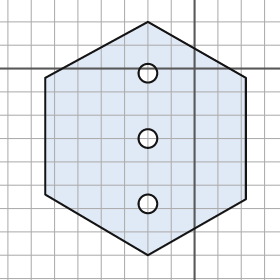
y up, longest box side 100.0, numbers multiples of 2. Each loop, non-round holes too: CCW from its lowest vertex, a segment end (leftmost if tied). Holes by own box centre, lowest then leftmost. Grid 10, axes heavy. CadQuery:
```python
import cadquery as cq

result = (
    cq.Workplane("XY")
    .moveTo(-20.0, -80.0)
    .lineTo(22.0, -56.0)
    .lineTo(22.0, -4.0)
    .lineTo(-20.0, 20.0)
    .lineTo(-64.0, -4.0)
    .lineTo(-64.0, -54.0)
    .close()
    .moveTo(-20.0, -58.0)
    .circle(4.0)
    .moveTo(-20.0, -30.0)
    .circle(4.0)
    .moveTo(-20.0, -2.0)
    .circle(4.0)
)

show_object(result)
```